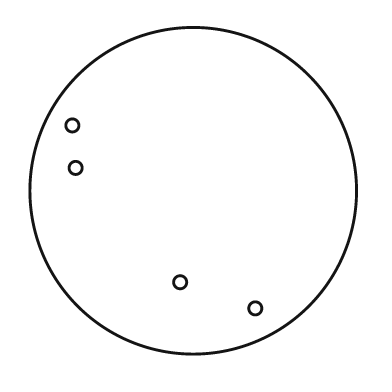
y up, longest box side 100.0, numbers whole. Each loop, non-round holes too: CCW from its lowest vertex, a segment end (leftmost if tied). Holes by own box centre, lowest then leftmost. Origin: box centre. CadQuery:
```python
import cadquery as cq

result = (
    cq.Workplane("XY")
    .moveTo(0.0, 0.0)
    .circle(50.0)
    .moveTo(19.0, -36.0)
    .circle(2.0)
    .moveTo(-4.0, -28.0)
    .circle(2.0)
    .moveTo(-36.0, 7.0)
    .circle(2.0)
    .moveTo(-37.0, 20.0)
    .circle(2.0)
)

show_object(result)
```